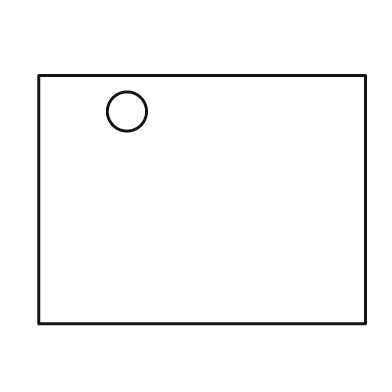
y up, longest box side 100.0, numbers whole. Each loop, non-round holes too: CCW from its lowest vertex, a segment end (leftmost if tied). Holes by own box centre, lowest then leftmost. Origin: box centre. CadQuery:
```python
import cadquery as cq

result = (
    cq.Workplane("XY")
    .moveTo(-50.0, -38.0)
    .lineTo(50.0, -38.0)
    .lineTo(50.0, 38.0)
    .lineTo(-50.0, 38.0)
    .close()
    .moveTo(-23.0, 27.0)
    .circle(6.0)
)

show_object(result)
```